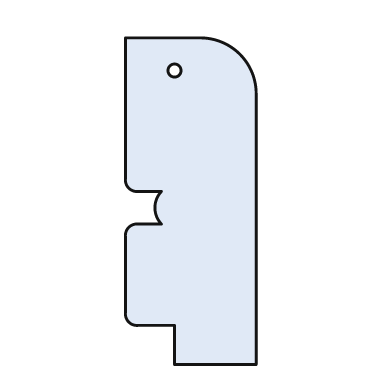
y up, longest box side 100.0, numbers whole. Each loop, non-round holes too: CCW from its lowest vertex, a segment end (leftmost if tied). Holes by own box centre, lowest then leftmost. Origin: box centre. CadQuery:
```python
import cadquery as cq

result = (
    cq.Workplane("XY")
    .moveTo(-5.0, -50.0)
    .lineTo(20.0, -50.0)
    .lineTo(20.0, 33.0)
    .threePointArc((15.0, 45.0), (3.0, 50.0))
    .lineTo(-20.0, 50.0)
    .lineTo(-20.0, 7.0)
    .threePointArc((-19.0, 4.0), (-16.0, 3.0))
    .lineTo(-9.0, 3.0)
    .threePointArc((-11.0, -2.0), (-9.0, -7.0))
    .lineTo(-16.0, -7.0)
    .threePointArc((-19.0, -8.0), (-20.0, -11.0))
    .lineTo(-20.0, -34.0)
    .threePointArc((-19.0, -37.0), (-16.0, -38.0))
    .lineTo(-5.0, -38.0)
    .close()
    .moveTo(-5.0, 40.0)
    .circle(2.0)
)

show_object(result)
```